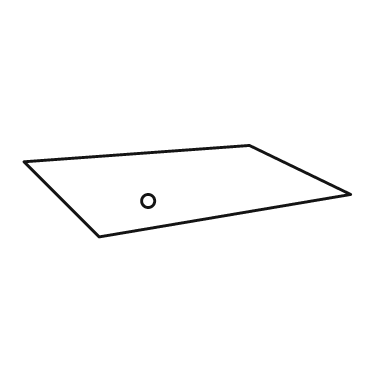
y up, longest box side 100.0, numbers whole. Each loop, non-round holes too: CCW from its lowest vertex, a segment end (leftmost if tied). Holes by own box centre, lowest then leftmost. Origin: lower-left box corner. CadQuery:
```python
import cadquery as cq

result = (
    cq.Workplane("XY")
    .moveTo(23.0, 0.0)
    .lineTo(100.0, 13.0)
    .lineTo(69.0, 28.0)
    .lineTo(0.0, 23.0)
    .close()
    .moveTo(38.0, 11.0)
    .circle(2.0)
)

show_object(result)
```